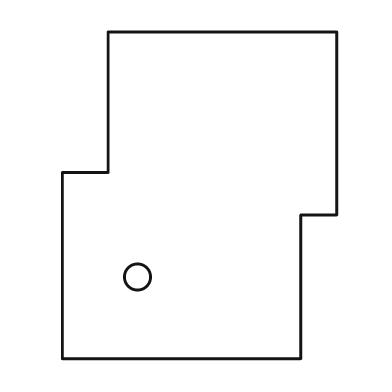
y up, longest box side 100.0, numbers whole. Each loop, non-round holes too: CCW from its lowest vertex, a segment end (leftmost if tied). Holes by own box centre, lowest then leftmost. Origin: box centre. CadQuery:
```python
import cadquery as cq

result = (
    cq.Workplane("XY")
    .moveTo(-42.0, -50.0)
    .lineTo(31.0, -50.0)
    .lineTo(31.0, -6.0)
    .lineTo(42.0, -6.0)
    .lineTo(42.0, 50.0)
    .lineTo(-28.0, 50.0)
    .lineTo(-28.0, 7.0)
    .lineTo(-42.0, 7.0)
    .close()
    .moveTo(-19.0, -25.0)
    .circle(4.0)
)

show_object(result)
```